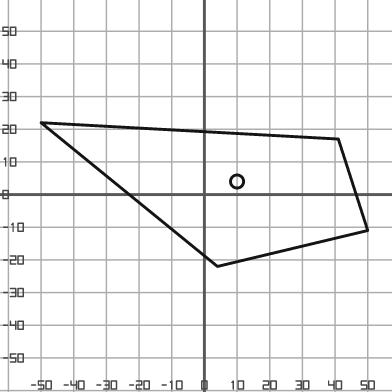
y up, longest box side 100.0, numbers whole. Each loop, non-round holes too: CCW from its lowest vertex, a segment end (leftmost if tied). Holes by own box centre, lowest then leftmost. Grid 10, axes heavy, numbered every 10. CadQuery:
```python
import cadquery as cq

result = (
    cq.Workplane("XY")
    .moveTo(4.0, -22.0)
    .lineTo(50.0, -11.0)
    .lineTo(41.0, 17.0)
    .lineTo(-50.0, 22.0)
    .close()
    .moveTo(10.0, 4.0)
    .circle(2.0)
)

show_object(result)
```